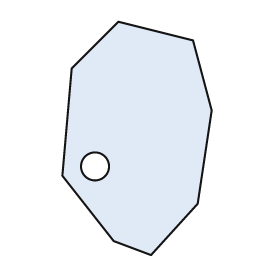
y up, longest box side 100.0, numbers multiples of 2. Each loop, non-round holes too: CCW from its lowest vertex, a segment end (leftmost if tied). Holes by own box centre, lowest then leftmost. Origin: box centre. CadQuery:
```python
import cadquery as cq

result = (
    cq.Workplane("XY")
    .moveTo(6.0, -50.0)
    .lineTo(26.0, -28.0)
    .lineTo(32.0, 12.0)
    .lineTo(24.0, 42.0)
    .lineTo(-8.0, 50.0)
    .lineTo(-28.0, 30.0)
    .lineTo(-32.0, -16.0)
    .lineTo(-10.0, -44.0)
    .close()
    .moveTo(-18.0, -12.0)
    .circle(6.0)
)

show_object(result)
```